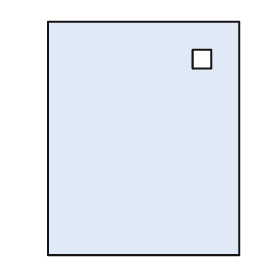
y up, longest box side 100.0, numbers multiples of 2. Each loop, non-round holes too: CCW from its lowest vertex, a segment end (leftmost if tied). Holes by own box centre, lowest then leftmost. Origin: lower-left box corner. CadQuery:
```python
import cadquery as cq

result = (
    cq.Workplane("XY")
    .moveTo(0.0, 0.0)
    .lineTo(82.0, 0.0)
    .lineTo(82.0, 100.0)
    .lineTo(0.0, 100.0)
    .close()
    .moveTo(62.0, 80.0)
    .lineTo(70.0, 80.0)
    .lineTo(70.0, 88.0)
    .lineTo(62.0, 88.0)
    .close()
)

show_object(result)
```